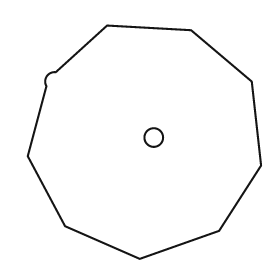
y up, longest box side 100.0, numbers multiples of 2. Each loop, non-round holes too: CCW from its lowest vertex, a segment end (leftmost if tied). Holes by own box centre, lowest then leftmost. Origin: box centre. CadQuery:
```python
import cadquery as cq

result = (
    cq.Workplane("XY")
    .moveTo(-2.0, -50.0)
    .lineTo(32.0, -38.0)
    .lineTo(50.0, -10.0)
    .lineTo(46.0, 26.0)
    .lineTo(20.0, 48.0)
    .lineTo(-16.0, 50.0)
    .lineTo(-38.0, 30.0)
    .threePointArc((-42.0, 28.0), (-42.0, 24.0))
    .lineTo(-50.0, -6.0)
    .lineTo(-34.0, -36.0)
    .close()
    .moveTo(4.0, 2.0)
    .circle(4.0)
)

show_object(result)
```